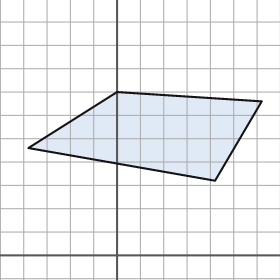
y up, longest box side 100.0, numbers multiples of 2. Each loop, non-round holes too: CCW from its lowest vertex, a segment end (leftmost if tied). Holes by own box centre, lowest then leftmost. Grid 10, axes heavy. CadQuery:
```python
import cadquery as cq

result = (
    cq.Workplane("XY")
    .moveTo(42.0, 32.0)
    .lineTo(62.0, 66.0)
    .lineTo(0.0, 70.0)
    .lineTo(-38.0, 46.0)
    .close()
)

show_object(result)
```